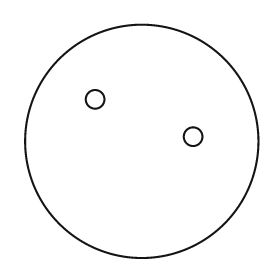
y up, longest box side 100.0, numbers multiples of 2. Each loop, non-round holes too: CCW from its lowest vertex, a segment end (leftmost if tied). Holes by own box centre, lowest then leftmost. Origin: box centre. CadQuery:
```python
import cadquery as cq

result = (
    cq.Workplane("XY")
    .moveTo(0.0, 0.0)
    .circle(50.0)
    .moveTo(22.0, 2.0)
    .circle(4.0)
    .moveTo(-20.0, 18.0)
    .circle(4.0)
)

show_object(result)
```